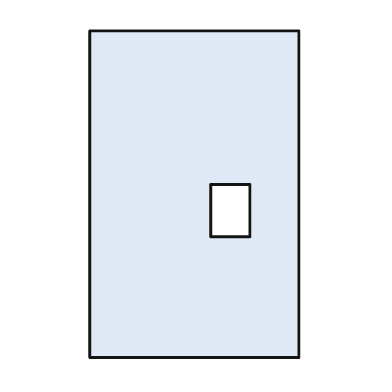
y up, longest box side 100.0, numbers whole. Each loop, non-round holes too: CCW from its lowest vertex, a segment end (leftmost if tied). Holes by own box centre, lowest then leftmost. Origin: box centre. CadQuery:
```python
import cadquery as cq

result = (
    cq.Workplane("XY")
    .moveTo(-32.0, -50.0)
    .lineTo(32.0, -50.0)
    .lineTo(32.0, 50.0)
    .lineTo(-32.0, 50.0)
    .close()
    .moveTo(5.0, -13.0)
    .lineTo(17.0, -13.0)
    .lineTo(17.0, 3.0)
    .lineTo(5.0, 3.0)
    .close()
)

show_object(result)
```